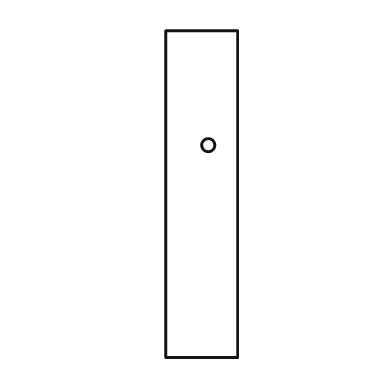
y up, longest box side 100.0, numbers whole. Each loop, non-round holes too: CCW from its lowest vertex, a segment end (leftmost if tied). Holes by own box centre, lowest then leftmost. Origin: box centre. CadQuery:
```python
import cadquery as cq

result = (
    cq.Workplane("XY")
    .moveTo(-11.0, -50.0)
    .lineTo(11.0, -50.0)
    .lineTo(11.0, 50.0)
    .lineTo(-11.0, 50.0)
    .close()
    .moveTo(2.0, 15.0)
    .circle(2.0)
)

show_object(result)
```